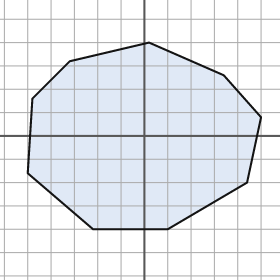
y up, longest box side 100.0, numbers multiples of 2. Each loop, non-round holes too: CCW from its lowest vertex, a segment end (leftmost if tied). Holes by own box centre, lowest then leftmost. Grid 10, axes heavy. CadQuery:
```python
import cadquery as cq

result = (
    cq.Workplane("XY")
    .moveTo(-22.0, -40.0)
    .lineTo(10.0, -40.0)
    .lineTo(44.0, -20.0)
    .lineTo(50.0, 8.0)
    .lineTo(34.0, 26.0)
    .lineTo(2.0, 40.0)
    .lineTo(-32.0, 32.0)
    .lineTo(-48.0, 16.0)
    .lineTo(-50.0, -16.0)
    .close()
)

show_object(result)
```